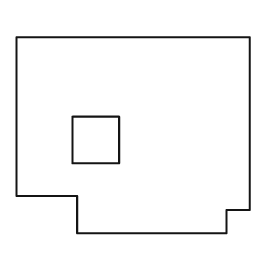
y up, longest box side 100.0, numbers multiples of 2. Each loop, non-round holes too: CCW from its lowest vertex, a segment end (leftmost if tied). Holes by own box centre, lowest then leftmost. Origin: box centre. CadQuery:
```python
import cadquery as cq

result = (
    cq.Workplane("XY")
    .moveTo(-24.0, -42.0)
    .lineTo(40.0, -42.0)
    .lineTo(40.0, -32.0)
    .lineTo(50.0, -32.0)
    .lineTo(50.0, 42.0)
    .lineTo(-50.0, 42.0)
    .lineTo(-50.0, -26.0)
    .lineTo(-24.0, -26.0)
    .close()
    .moveTo(-26.0, -12.0)
    .lineTo(-6.0, -12.0)
    .lineTo(-6.0, 8.0)
    .lineTo(-26.0, 8.0)
    .close()
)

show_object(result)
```